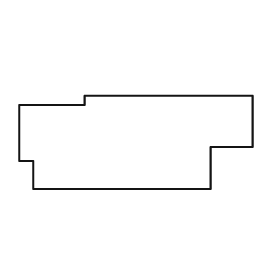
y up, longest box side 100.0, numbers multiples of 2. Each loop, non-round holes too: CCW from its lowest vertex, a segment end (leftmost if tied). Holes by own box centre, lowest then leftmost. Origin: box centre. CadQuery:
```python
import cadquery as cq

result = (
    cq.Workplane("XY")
    .moveTo(-44.0, -20.0)
    .lineTo(32.0, -20.0)
    .lineTo(32.0, -2.0)
    .lineTo(50.0, -2.0)
    .lineTo(50.0, 20.0)
    .lineTo(-22.0, 20.0)
    .lineTo(-22.0, 16.0)
    .lineTo(-50.0, 16.0)
    .lineTo(-50.0, -8.0)
    .lineTo(-44.0, -8.0)
    .close()
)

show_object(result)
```